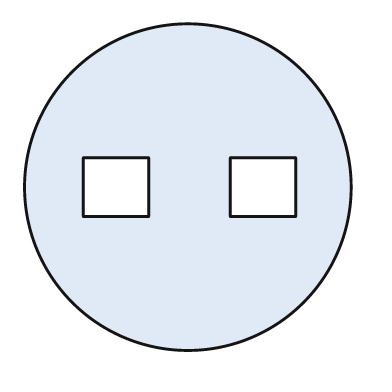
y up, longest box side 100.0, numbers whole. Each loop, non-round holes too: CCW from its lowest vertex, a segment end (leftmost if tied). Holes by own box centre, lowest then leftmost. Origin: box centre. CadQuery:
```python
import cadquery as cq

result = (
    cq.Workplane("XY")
    .moveTo(0.0, 0.0)
    .circle(50.0)
    .moveTo(-32.0, -9.0)
    .lineTo(-12.0, -9.0)
    .lineTo(-12.0, 9.0)
    .lineTo(-32.0, 9.0)
    .close()
    .moveTo(13.0, -9.0)
    .lineTo(33.0, -9.0)
    .lineTo(33.0, 9.0)
    .lineTo(13.0, 9.0)
    .close()
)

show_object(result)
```